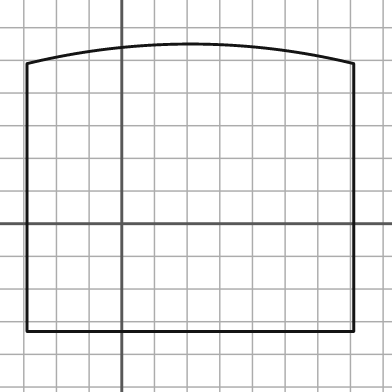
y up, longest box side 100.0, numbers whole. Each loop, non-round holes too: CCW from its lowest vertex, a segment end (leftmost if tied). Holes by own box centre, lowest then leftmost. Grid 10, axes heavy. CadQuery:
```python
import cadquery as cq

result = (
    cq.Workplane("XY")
    .moveTo(-29.0, -33.0)
    .lineTo(71.0, -33.0)
    .lineTo(71.0, 49.0)
    .threePointArc((21.0, 55.0), (-29.0, 49.0))
    .close()
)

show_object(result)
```